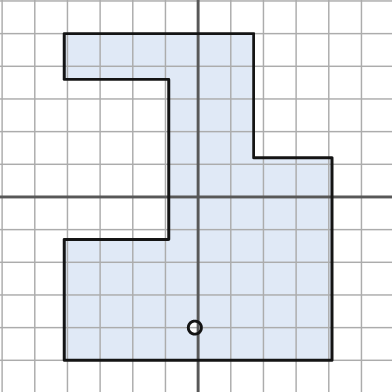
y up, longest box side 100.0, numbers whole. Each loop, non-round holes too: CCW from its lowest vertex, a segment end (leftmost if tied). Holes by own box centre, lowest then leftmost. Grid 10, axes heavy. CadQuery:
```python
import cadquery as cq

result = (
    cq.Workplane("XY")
    .moveTo(-41.0, -50.0)
    .lineTo(41.0, -50.0)
    .lineTo(41.0, 12.0)
    .lineTo(17.0, 12.0)
    .lineTo(17.0, 50.0)
    .lineTo(-41.0, 50.0)
    .lineTo(-41.0, 36.0)
    .lineTo(-9.0, 36.0)
    .lineTo(-9.0, -13.0)
    .lineTo(-41.0, -13.0)
    .close()
    .moveTo(-1.0, -40.0)
    .circle(2.0)
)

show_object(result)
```